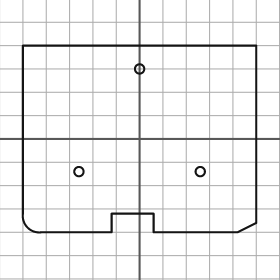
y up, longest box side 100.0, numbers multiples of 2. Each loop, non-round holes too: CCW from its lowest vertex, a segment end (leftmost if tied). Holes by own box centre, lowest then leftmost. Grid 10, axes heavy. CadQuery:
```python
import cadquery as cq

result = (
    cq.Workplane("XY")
    .moveTo(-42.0, -40.0)
    .lineTo(-12.0, -40.0)
    .lineTo(-12.0, -32.0)
    .lineTo(6.0, -32.0)
    .lineTo(6.0, -40.0)
    .lineTo(42.0, -40.0)
    .lineTo(50.0, -36.0)
    .lineTo(50.0, 40.0)
    .lineTo(-50.0, 40.0)
    .lineTo(-50.0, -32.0)
    .threePointArc((-48.0, -38.0), (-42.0, -40.0))
    .close()
    .moveTo(-26.0, -14.0)
    .circle(2.0)
    .moveTo(26.0, -14.0)
    .circle(2.0)
    .moveTo(0.0, 30.0)
    .circle(2.0)
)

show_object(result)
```